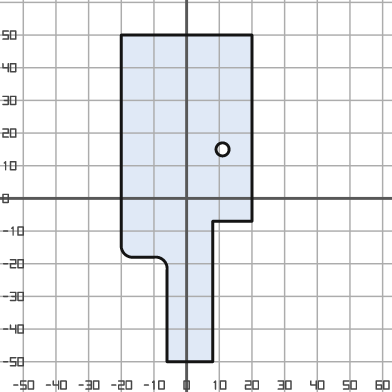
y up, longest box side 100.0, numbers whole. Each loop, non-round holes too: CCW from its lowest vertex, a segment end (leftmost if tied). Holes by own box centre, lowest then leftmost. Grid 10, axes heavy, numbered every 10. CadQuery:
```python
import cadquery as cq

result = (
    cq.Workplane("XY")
    .moveTo(-6.0, -50.0)
    .lineTo(8.0, -50.0)
    .lineTo(8.0, -7.0)
    .lineTo(20.0, -7.0)
    .lineTo(20.0, 50.0)
    .lineTo(-20.0, 50.0)
    .lineTo(-20.0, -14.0)
    .threePointArc((-19.0, -17.0), (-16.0, -18.0))
    .lineTo(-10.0, -18.0)
    .threePointArc((-7.0, -19.0), (-6.0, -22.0))
    .close()
    .moveTo(11.0, 15.0)
    .circle(2.0)
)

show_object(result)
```